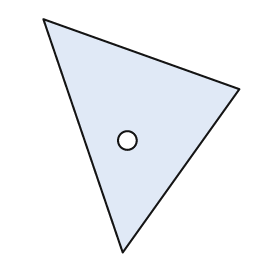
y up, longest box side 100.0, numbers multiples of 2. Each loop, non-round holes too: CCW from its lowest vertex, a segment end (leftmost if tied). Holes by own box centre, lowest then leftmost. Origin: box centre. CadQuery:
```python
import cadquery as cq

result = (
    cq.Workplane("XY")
    .moveTo(-8.0, -50.0)
    .lineTo(42.0, 20.0)
    .lineTo(-42.0, 50.0)
    .close()
    .moveTo(-6.0, -2.0)
    .circle(4.0)
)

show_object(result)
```